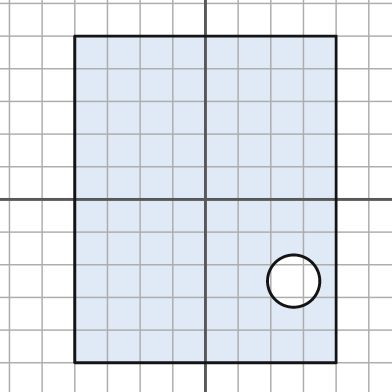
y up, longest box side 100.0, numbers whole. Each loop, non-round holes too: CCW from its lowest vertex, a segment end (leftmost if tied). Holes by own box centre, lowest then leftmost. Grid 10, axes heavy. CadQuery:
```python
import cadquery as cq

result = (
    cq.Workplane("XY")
    .moveTo(-40.0, -50.0)
    .lineTo(40.0, -50.0)
    .lineTo(40.0, 50.0)
    .lineTo(-40.0, 50.0)
    .close()
    .moveTo(27.0, -25.0)
    .circle(8.0)
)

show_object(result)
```